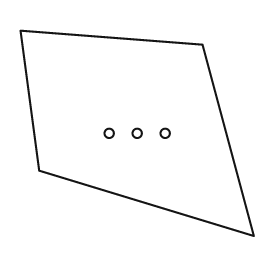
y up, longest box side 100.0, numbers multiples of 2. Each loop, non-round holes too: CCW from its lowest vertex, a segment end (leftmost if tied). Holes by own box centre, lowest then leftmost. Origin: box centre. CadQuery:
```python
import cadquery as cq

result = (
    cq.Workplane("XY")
    .moveTo(50.0, -44.0)
    .lineTo(28.0, 38.0)
    .lineTo(-50.0, 44.0)
    .lineTo(-42.0, -16.0)
    .close()
    .moveTo(-12.0, 0.0)
    .circle(2.0)
    .moveTo(0.0, 0.0)
    .circle(2.0)
    .moveTo(12.0, 0.0)
    .circle(2.0)
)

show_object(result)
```